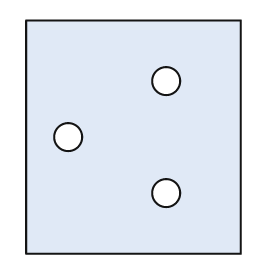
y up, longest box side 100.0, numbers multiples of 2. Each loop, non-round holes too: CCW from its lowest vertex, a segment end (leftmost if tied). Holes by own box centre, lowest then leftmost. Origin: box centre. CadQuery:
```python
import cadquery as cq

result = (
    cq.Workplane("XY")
    .moveTo(-46.0, -50.0)
    .lineTo(46.0, -50.0)
    .lineTo(46.0, 50.0)
    .lineTo(-46.0, 50.0)
    .close()
    .moveTo(14.0, -24.0)
    .circle(6.0)
    .moveTo(-28.0, 0.0)
    .circle(6.0)
    .moveTo(14.0, 24.0)
    .circle(6.0)
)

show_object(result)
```